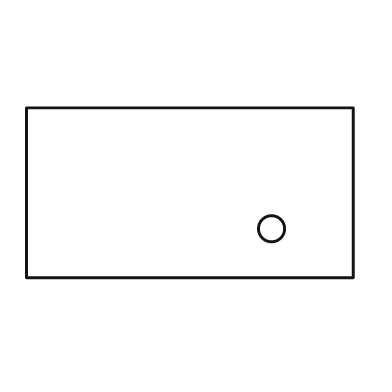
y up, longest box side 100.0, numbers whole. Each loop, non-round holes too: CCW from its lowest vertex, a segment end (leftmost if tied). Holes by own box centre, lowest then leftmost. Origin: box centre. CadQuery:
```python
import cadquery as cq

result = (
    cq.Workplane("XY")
    .moveTo(-50.0, -26.0)
    .lineTo(50.0, -26.0)
    .lineTo(50.0, 26.0)
    .lineTo(-50.0, 26.0)
    .close()
    .moveTo(25.0, -11.0)
    .circle(4.0)
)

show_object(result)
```